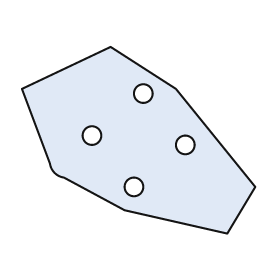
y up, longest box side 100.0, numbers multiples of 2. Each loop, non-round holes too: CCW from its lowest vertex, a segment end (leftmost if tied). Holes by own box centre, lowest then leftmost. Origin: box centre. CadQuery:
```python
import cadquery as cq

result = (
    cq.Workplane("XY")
    .moveTo(38.0, -40.0)
    .lineTo(50.0, -20.0)
    .lineTo(16.0, 22.0)
    .lineTo(-12.0, 40.0)
    .lineTo(-50.0, 22.0)
    .lineTo(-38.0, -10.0)
    .threePointArc((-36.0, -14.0), (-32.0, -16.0))
    .lineTo(-6.0, -30.0)
    .close()
    .moveTo(-2.0, -20.0)
    .circle(4.0)
    .moveTo(20.0, -2.0)
    .circle(4.0)
    .moveTo(-20.0, 2.0)
    .circle(4.0)
    .moveTo(2.0, 20.0)
    .circle(4.0)
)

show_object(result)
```